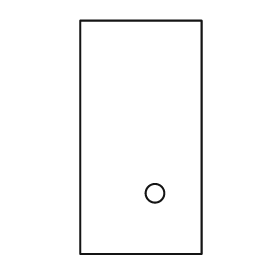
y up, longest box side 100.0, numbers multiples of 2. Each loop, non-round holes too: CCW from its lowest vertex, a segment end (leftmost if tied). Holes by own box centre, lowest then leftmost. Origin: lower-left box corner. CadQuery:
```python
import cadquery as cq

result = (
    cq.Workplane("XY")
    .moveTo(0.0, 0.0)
    .lineTo(52.0, 0.0)
    .lineTo(52.0, 100.0)
    .lineTo(0.0, 100.0)
    .close()
    .moveTo(32.0, 26.0)
    .circle(4.0)
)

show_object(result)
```